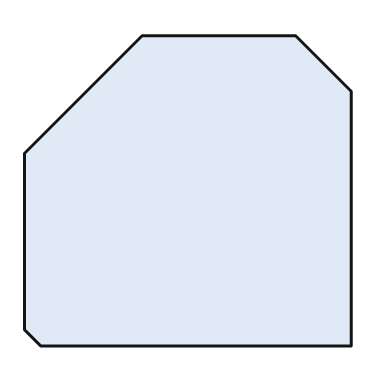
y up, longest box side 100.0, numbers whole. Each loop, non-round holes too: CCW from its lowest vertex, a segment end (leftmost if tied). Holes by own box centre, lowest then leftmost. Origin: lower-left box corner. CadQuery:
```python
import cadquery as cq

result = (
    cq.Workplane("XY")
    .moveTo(5.0, 0.0)
    .lineTo(100.0, 0.0)
    .lineTo(100.0, 78.0)
    .lineTo(83.0, 95.0)
    .lineTo(36.0, 95.0)
    .lineTo(0.0, 59.0)
    .lineTo(0.0, 5.0)
    .close()
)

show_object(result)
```